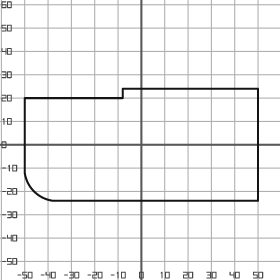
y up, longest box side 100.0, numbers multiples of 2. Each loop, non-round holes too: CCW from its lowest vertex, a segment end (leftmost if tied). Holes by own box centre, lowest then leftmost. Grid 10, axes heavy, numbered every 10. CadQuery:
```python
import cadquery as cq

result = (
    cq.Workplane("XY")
    .moveTo(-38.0, -24.0)
    .lineTo(50.0, -24.0)
    .lineTo(50.0, 24.0)
    .lineTo(-8.0, 24.0)
    .lineTo(-8.0, 20.0)
    .lineTo(-50.0, 20.0)
    .lineTo(-50.0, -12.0)
    .threePointArc((-46.0, -20.0), (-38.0, -24.0))
    .close()
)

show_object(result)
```